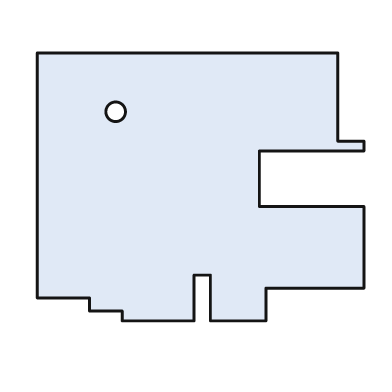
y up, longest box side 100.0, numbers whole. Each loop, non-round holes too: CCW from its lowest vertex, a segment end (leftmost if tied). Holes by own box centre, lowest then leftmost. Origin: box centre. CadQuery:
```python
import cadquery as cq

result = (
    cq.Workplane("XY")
    .moveTo(-24.0, -41.0)
    .lineTo(-2.0, -41.0)
    .lineTo(-2.0, -27.0)
    .lineTo(3.0, -27.0)
    .lineTo(3.0, -41.0)
    .lineTo(20.0, -41.0)
    .lineTo(20.0, -31.0)
    .lineTo(50.0, -31.0)
    .lineTo(50.0, -6.0)
    .lineTo(18.0, -6.0)
    .lineTo(18.0, 11.0)
    .lineTo(50.0, 11.0)
    .lineTo(50.0, 14.0)
    .lineTo(42.0, 14.0)
    .lineTo(42.0, 41.0)
    .lineTo(-50.0, 41.0)
    .lineTo(-50.0, -34.0)
    .lineTo(-34.0, -34.0)
    .lineTo(-34.0, -38.0)
    .lineTo(-24.0, -38.0)
    .close()
    .moveTo(-26.0, 23.0)
    .circle(3.0)
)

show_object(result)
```